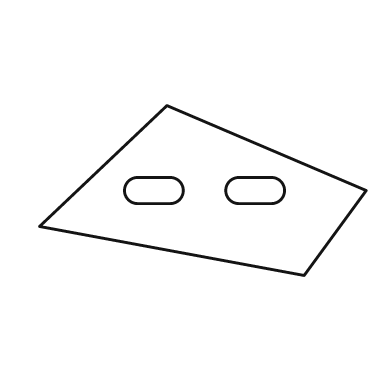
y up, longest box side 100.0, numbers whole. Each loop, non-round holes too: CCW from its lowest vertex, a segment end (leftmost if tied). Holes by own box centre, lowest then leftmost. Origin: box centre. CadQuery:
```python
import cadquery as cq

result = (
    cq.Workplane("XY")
    .moveTo(31.0, -26.0)
    .lineTo(50.0, 0.0)
    .lineTo(-11.0, 26.0)
    .lineTo(-50.0, -11.0)
    .close()
    .moveTo(-20.0, -4.0)
    .lineTo(-10.0, -4.0)
    .threePointArc((-6.0, 0.0), (-10.0, 4.0))
    .lineTo(-20.0, 4.0)
    .threePointArc((-24.0, 0.0), (-20.0, -4.0))
    .close()
    .moveTo(11.0, -4.0)
    .lineTo(21.0, -4.0)
    .threePointArc((25.0, 0.0), (21.0, 4.0))
    .lineTo(11.0, 4.0)
    .threePointArc((7.0, 0.0), (11.0, -4.0))
    .close()
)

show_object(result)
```